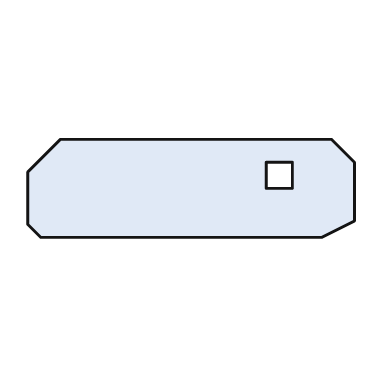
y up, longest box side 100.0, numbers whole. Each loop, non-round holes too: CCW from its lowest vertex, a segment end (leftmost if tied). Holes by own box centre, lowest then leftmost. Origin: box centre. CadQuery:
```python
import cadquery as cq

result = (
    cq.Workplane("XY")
    .moveTo(-46.0, -15.0)
    .lineTo(40.0, -15.0)
    .lineTo(50.0, -10.0)
    .lineTo(50.0, 8.0)
    .lineTo(43.0, 15.0)
    .lineTo(-40.0, 15.0)
    .lineTo(-50.0, 5.0)
    .lineTo(-50.0, -11.0)
    .close()
    .moveTo(23.0, 0.0)
    .lineTo(31.0, 0.0)
    .lineTo(31.0, 8.0)
    .lineTo(23.0, 8.0)
    .close()
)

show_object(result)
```